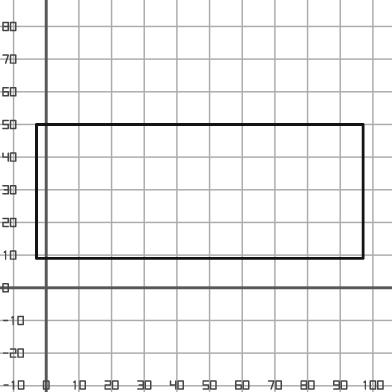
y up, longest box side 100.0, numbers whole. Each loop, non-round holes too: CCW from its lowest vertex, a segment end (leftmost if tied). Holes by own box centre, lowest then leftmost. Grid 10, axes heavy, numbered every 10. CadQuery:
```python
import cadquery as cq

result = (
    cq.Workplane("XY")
    .moveTo(-3.0, 9.0)
    .lineTo(97.0, 9.0)
    .lineTo(97.0, 50.0)
    .lineTo(-3.0, 50.0)
    .close()
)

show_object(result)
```